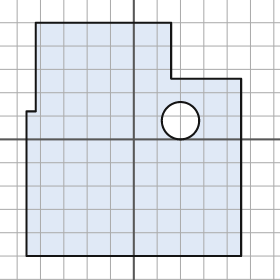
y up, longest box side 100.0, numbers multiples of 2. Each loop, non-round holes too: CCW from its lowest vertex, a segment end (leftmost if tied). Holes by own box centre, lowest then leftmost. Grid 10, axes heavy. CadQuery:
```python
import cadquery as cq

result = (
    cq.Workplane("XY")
    .moveTo(-46.0, -50.0)
    .lineTo(46.0, -50.0)
    .lineTo(46.0, 26.0)
    .lineTo(16.0, 26.0)
    .lineTo(16.0, 50.0)
    .lineTo(-42.0, 50.0)
    .lineTo(-42.0, 12.0)
    .lineTo(-46.0, 12.0)
    .close()
    .moveTo(20.0, 8.0)
    .circle(8.0)
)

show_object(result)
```